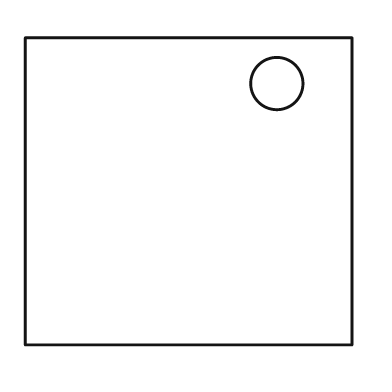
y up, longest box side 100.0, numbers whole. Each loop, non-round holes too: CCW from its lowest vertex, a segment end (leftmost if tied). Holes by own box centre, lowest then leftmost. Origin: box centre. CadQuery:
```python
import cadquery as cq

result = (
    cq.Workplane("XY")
    .moveTo(-50.0, -47.0)
    .lineTo(50.0, -47.0)
    .lineTo(50.0, 47.0)
    .lineTo(-50.0, 47.0)
    .close()
    .moveTo(27.0, 33.0)
    .circle(8.0)
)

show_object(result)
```